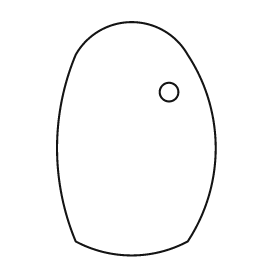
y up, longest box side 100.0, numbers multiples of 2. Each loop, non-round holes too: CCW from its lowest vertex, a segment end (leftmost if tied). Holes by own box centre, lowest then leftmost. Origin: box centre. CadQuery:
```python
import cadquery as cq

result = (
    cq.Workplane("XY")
    .moveTo(-26.0, -44.0)
    .threePointArc((-2.0, -50.0), (22.0, -44.0))
    .threePointArc((34.0, -4.0), (22.0, 36.0))
    .threePointArc((-2.0, 50.0), (-26.0, 36.0))
    .threePointArc((-34.0, -4.0), (-26.0, -44.0))
    .close()
    .moveTo(14.0, 20.0)
    .circle(4.0)
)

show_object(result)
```